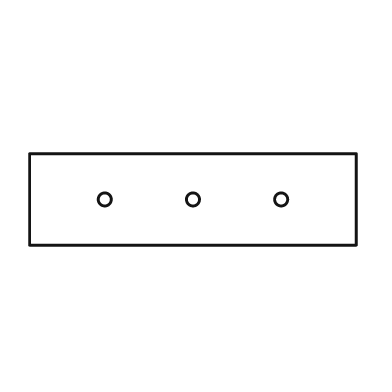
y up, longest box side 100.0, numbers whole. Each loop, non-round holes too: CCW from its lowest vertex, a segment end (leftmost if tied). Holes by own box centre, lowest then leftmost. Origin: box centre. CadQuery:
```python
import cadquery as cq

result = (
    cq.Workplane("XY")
    .moveTo(-50.0, -14.0)
    .lineTo(50.0, -14.0)
    .lineTo(50.0, 14.0)
    .lineTo(-50.0, 14.0)
    .close()
    .moveTo(-27.0, 0.0)
    .circle(2.0)
    .moveTo(0.0, 0.0)
    .circle(2.0)
    .moveTo(27.0, 0.0)
    .circle(2.0)
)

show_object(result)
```